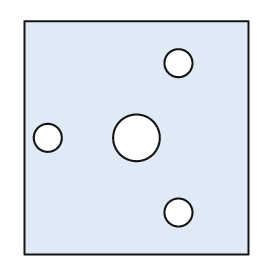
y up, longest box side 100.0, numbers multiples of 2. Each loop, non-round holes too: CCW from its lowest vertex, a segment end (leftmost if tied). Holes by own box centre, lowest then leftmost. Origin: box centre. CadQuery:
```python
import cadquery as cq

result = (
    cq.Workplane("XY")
    .moveTo(-48.0, -50.0)
    .lineTo(48.0, -50.0)
    .lineTo(48.0, 50.0)
    .lineTo(-48.0, 50.0)
    .close()
    .moveTo(18.0, -32.0)
    .circle(6.0)
    .moveTo(-38.0, 0.0)
    .circle(6.0)
    .moveTo(0.0, 0.0)
    .circle(10.0)
    .moveTo(18.0, 32.0)
    .circle(6.0)
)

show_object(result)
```